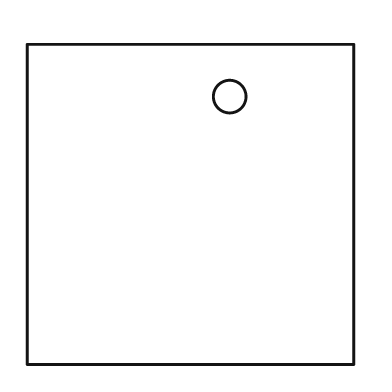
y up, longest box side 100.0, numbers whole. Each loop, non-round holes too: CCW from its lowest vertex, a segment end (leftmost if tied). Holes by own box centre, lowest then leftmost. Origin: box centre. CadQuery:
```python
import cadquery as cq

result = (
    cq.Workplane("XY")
    .moveTo(-50.0, -49.0)
    .lineTo(50.0, -49.0)
    .lineTo(50.0, 49.0)
    .lineTo(-50.0, 49.0)
    .close()
    .moveTo(12.0, 33.0)
    .circle(5.0)
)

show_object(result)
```